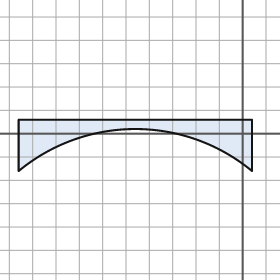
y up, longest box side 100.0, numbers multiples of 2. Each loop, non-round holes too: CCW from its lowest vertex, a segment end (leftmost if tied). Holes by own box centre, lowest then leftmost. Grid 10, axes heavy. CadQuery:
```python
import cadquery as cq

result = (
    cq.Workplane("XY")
    .moveTo(-96.0, -16.0)
    .threePointArc((-46.0, 2.0), (4.0, -16.0))
    .lineTo(4.0, 6.0)
    .lineTo(-96.0, 6.0)
    .close()
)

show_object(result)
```